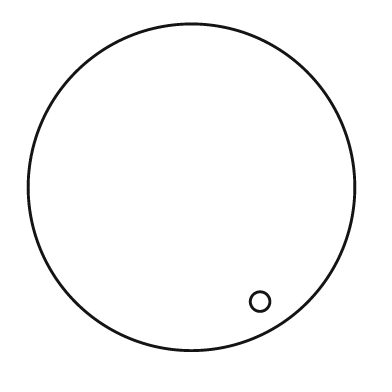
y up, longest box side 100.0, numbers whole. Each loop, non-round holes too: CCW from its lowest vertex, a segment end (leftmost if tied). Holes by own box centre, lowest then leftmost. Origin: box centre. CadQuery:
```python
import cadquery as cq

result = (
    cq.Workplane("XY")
    .moveTo(0.0, 0.0)
    .circle(50.0)
    .moveTo(21.0, -35.0)
    .circle(3.0)
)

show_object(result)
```